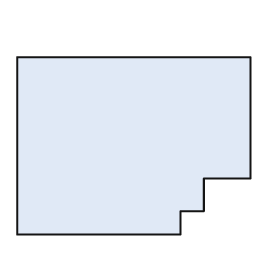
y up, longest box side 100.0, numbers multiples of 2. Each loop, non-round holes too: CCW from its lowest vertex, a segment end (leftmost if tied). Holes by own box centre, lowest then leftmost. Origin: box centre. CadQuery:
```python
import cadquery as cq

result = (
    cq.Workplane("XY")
    .moveTo(-50.0, -38.0)
    .lineTo(20.0, -38.0)
    .lineTo(20.0, -28.0)
    .lineTo(30.0, -28.0)
    .lineTo(30.0, -14.0)
    .lineTo(50.0, -14.0)
    .lineTo(50.0, 38.0)
    .lineTo(-50.0, 38.0)
    .close()
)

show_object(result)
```